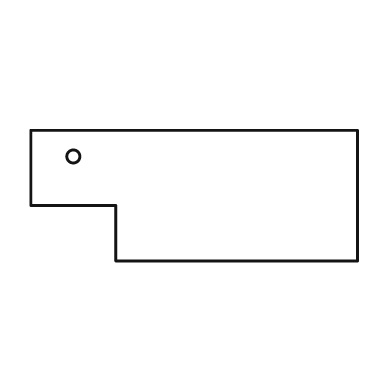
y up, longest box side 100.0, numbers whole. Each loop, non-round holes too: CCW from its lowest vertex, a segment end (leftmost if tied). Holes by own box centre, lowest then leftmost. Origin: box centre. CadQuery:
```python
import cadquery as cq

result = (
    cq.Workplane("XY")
    .moveTo(-24.0, -20.0)
    .lineTo(50.0, -20.0)
    .lineTo(50.0, 20.0)
    .lineTo(-50.0, 20.0)
    .lineTo(-50.0, -3.0)
    .lineTo(-24.0, -3.0)
    .close()
    .moveTo(-37.0, 12.0)
    .circle(2.0)
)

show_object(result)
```